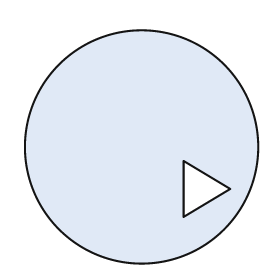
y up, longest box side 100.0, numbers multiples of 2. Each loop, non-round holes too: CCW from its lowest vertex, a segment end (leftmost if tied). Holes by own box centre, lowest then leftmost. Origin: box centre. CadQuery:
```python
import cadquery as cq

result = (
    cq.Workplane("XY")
    .moveTo(0.0, 0.0)
    .circle(50.0)
    .moveTo(18.0, -30.0)
    .lineTo(38.0, -18.0)
    .lineTo(18.0, -6.0)
    .close()
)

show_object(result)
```